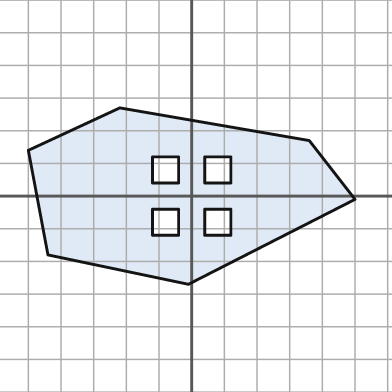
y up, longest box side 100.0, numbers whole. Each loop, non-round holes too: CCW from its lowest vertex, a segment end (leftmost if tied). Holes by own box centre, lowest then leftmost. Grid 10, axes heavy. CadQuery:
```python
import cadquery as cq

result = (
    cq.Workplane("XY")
    .moveTo(-1.0, -27.0)
    .lineTo(50.0, -1.0)
    .lineTo(36.0, 17.0)
    .lineTo(-22.0, 27.0)
    .lineTo(-50.0, 14.0)
    .lineTo(-44.0, -18.0)
    .close()
    .moveTo(-12.0, -12.0)
    .lineTo(-4.0, -12.0)
    .lineTo(-4.0, -4.0)
    .lineTo(-12.0, -4.0)
    .close()
    .moveTo(4.0, -12.0)
    .lineTo(12.0, -12.0)
    .lineTo(12.0, -4.0)
    .lineTo(4.0, -4.0)
    .close()
    .moveTo(-12.0, 4.0)
    .lineTo(-4.0, 4.0)
    .lineTo(-4.0, 12.0)
    .lineTo(-12.0, 12.0)
    .close()
    .moveTo(4.0, 4.0)
    .lineTo(12.0, 4.0)
    .lineTo(12.0, 12.0)
    .lineTo(4.0, 12.0)
    .close()
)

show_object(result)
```